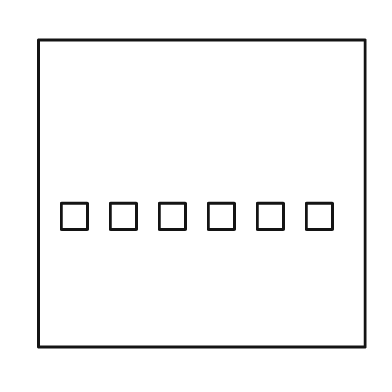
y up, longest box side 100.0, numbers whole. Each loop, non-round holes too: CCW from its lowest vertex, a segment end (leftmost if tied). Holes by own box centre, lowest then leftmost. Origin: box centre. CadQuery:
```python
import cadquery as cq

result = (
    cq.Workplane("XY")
    .moveTo(-50.0, -47.0)
    .lineTo(50.0, -47.0)
    .lineTo(50.0, 47.0)
    .lineTo(-50.0, 47.0)
    .close()
    .moveTo(-43.0, -11.0)
    .lineTo(-35.0, -11.0)
    .lineTo(-35.0, -3.0)
    .lineTo(-43.0, -3.0)
    .close()
    .moveTo(-28.0, -11.0)
    .lineTo(-20.0, -11.0)
    .lineTo(-20.0, -3.0)
    .lineTo(-28.0, -3.0)
    .close()
    .moveTo(-13.0, -11.0)
    .lineTo(-5.0, -11.0)
    .lineTo(-5.0, -3.0)
    .lineTo(-13.0, -3.0)
    .close()
    .moveTo(2.0, -11.0)
    .lineTo(10.0, -11.0)
    .lineTo(10.0, -3.0)
    .lineTo(2.0, -3.0)
    .close()
    .moveTo(17.0, -11.0)
    .lineTo(25.0, -11.0)
    .lineTo(25.0, -3.0)
    .lineTo(17.0, -3.0)
    .close()
    .moveTo(32.0, -11.0)
    .lineTo(40.0, -11.0)
    .lineTo(40.0, -3.0)
    .lineTo(32.0, -3.0)
    .close()
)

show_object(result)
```